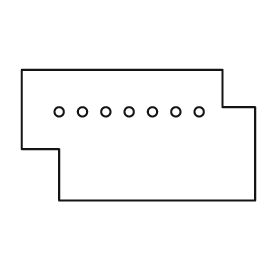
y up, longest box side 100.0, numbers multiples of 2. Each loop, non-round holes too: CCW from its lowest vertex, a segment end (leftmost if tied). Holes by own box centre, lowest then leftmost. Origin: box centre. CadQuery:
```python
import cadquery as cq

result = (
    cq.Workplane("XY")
    .moveTo(-34.0, -28.0)
    .lineTo(50.0, -28.0)
    .lineTo(50.0, 12.0)
    .lineTo(36.0, 12.0)
    .lineTo(36.0, 28.0)
    .lineTo(-50.0, 28.0)
    .lineTo(-50.0, -6.0)
    .lineTo(-34.0, -6.0)
    .close()
    .moveTo(-34.0, 10.0)
    .circle(2.0)
    .moveTo(-24.0, 10.0)
    .circle(2.0)
    .moveTo(-14.0, 10.0)
    .circle(2.0)
    .moveTo(-4.0, 10.0)
    .circle(2.0)
    .moveTo(6.0, 10.0)
    .circle(2.0)
    .moveTo(16.0, 10.0)
    .circle(2.0)
    .moveTo(26.0, 10.0)
    .circle(2.0)
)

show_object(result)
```